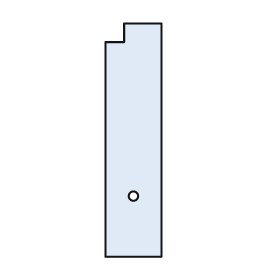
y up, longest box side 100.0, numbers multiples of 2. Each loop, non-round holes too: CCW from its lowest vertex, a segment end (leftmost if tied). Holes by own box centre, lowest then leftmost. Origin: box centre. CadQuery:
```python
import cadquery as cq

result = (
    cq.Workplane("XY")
    .moveTo(-12.0, -50.0)
    .lineTo(12.0, -50.0)
    .lineTo(12.0, 50.0)
    .lineTo(-4.0, 50.0)
    .lineTo(-4.0, 42.0)
    .lineTo(-12.0, 42.0)
    .close()
    .moveTo(0.0, -24.0)
    .circle(2.0)
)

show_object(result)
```